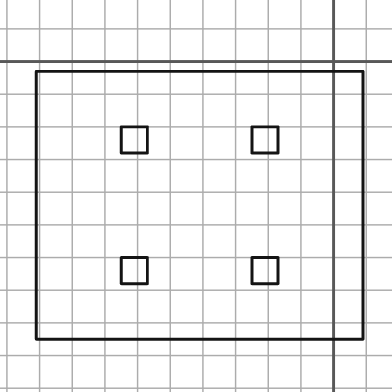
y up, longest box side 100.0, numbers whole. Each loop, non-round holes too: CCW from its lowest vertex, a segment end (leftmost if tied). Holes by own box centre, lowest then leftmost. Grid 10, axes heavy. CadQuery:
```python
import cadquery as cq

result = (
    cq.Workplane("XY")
    .moveTo(-91.0, -85.0)
    .lineTo(9.0, -85.0)
    .lineTo(9.0, -3.0)
    .lineTo(-91.0, -3.0)
    .close()
    .moveTo(-65.0, -68.0)
    .lineTo(-57.0, -68.0)
    .lineTo(-57.0, -60.0)
    .lineTo(-65.0, -60.0)
    .close()
    .moveTo(-25.0, -68.0)
    .lineTo(-17.0, -68.0)
    .lineTo(-17.0, -60.0)
    .lineTo(-25.0, -60.0)
    .close()
    .moveTo(-65.0, -28.0)
    .lineTo(-57.0, -28.0)
    .lineTo(-57.0, -20.0)
    .lineTo(-65.0, -20.0)
    .close()
    .moveTo(-25.0, -28.0)
    .lineTo(-17.0, -28.0)
    .lineTo(-17.0, -20.0)
    .lineTo(-25.0, -20.0)
    .close()
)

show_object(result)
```